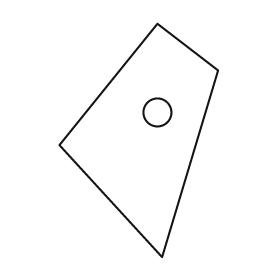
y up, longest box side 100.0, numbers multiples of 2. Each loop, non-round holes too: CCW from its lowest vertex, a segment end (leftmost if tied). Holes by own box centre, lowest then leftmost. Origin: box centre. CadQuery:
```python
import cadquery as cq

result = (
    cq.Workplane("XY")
    .moveTo(10.0, -50.0)
    .lineTo(34.0, 30.0)
    .lineTo(8.0, 50.0)
    .lineTo(-34.0, -2.0)
    .close()
    .moveTo(8.0, 12.0)
    .circle(6.0)
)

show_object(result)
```